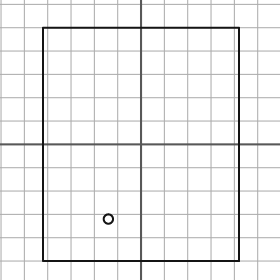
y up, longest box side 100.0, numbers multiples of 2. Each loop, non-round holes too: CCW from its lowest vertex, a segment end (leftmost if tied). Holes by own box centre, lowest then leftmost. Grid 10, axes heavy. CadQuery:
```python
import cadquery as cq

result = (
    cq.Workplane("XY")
    .moveTo(-42.0, -50.0)
    .lineTo(42.0, -50.0)
    .lineTo(42.0, 50.0)
    .lineTo(-42.0, 50.0)
    .close()
    .moveTo(-14.0, -32.0)
    .circle(2.0)
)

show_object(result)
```